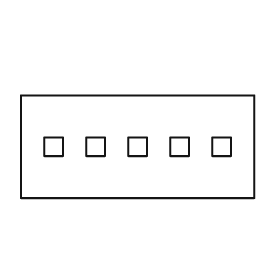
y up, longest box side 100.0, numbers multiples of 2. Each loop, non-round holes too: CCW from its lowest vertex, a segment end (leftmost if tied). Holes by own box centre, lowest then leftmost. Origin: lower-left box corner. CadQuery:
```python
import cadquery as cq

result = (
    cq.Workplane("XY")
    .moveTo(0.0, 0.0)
    .lineTo(100.0, 0.0)
    .lineTo(100.0, 44.0)
    .lineTo(0.0, 44.0)
    .close()
    .moveTo(10.0, 18.0)
    .lineTo(18.0, 18.0)
    .lineTo(18.0, 26.0)
    .lineTo(10.0, 26.0)
    .close()
    .moveTo(28.0, 18.0)
    .lineTo(36.0, 18.0)
    .lineTo(36.0, 26.0)
    .lineTo(28.0, 26.0)
    .close()
    .moveTo(46.0, 18.0)
    .lineTo(54.0, 18.0)
    .lineTo(54.0, 26.0)
    .lineTo(46.0, 26.0)
    .close()
    .moveTo(64.0, 18.0)
    .lineTo(72.0, 18.0)
    .lineTo(72.0, 26.0)
    .lineTo(64.0, 26.0)
    .close()
    .moveTo(82.0, 18.0)
    .lineTo(90.0, 18.0)
    .lineTo(90.0, 26.0)
    .lineTo(82.0, 26.0)
    .close()
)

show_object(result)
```